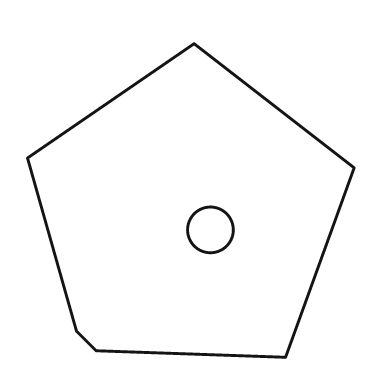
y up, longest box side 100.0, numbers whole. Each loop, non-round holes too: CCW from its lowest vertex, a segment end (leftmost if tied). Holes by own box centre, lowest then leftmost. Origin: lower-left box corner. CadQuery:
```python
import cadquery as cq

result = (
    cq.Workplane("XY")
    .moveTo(79.0, 0.0)
    .lineTo(100.0, 58.0)
    .lineTo(51.0, 96.0)
    .lineTo(0.0, 61.0)
    .lineTo(15.0, 8.0)
    .lineTo(21.0, 2.0)
    .close()
    .moveTo(56.0, 39.0)
    .circle(7.0)
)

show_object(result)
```